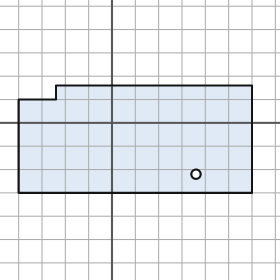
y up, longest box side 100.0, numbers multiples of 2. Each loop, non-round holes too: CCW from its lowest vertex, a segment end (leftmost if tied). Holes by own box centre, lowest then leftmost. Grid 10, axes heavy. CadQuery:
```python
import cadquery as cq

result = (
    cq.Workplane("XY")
    .moveTo(-40.0, -30.0)
    .lineTo(60.0, -30.0)
    .lineTo(60.0, 16.0)
    .lineTo(-24.0, 16.0)
    .lineTo(-24.0, 10.0)
    .lineTo(-40.0, 10.0)
    .close()
    .moveTo(36.0, -22.0)
    .circle(2.0)
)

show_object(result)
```